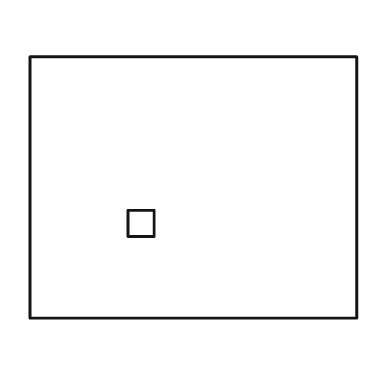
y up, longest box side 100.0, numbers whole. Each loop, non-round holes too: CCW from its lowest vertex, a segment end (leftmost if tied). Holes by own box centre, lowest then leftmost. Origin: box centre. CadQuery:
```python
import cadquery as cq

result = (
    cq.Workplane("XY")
    .moveTo(-50.0, -40.0)
    .lineTo(50.0, -40.0)
    .lineTo(50.0, 40.0)
    .lineTo(-50.0, 40.0)
    .close()
    .moveTo(-20.0, -15.0)
    .lineTo(-12.0, -15.0)
    .lineTo(-12.0, -7.0)
    .lineTo(-20.0, -7.0)
    .close()
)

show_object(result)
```